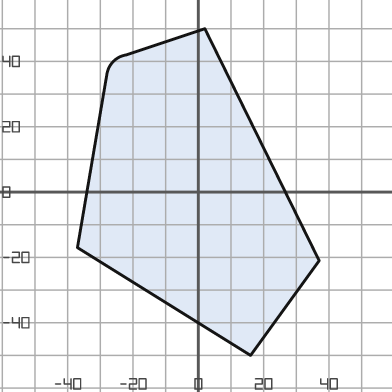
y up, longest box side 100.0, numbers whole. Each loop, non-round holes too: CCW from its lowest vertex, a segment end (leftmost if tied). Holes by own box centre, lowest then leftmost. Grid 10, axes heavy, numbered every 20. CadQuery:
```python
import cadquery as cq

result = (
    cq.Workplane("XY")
    .moveTo(16.0, -50.0)
    .lineTo(37.0, -21.0)
    .lineTo(2.0, 50.0)
    .lineTo(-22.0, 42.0)
    .threePointArc((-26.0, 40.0), (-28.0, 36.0))
    .lineTo(-37.0, -17.0)
    .close()
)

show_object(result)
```